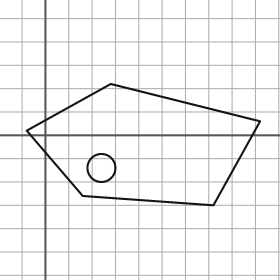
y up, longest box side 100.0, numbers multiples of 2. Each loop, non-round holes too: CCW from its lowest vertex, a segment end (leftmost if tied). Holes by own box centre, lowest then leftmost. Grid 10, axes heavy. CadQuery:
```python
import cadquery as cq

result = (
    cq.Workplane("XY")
    .moveTo(72.0, -30.0)
    .lineTo(92.0, 6.0)
    .lineTo(28.0, 22.0)
    .lineTo(-8.0, 2.0)
    .lineTo(16.0, -26.0)
    .close()
    .moveTo(24.0, -14.0)
    .circle(6.0)
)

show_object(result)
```